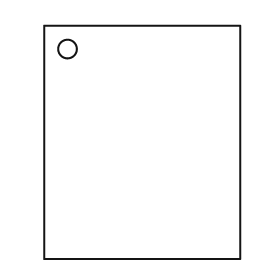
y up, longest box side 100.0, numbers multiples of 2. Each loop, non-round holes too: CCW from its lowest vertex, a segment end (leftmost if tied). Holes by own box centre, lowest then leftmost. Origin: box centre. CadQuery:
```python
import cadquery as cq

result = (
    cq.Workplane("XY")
    .moveTo(-42.0, -50.0)
    .lineTo(42.0, -50.0)
    .lineTo(42.0, 50.0)
    .lineTo(-42.0, 50.0)
    .close()
    .moveTo(-32.0, 40.0)
    .circle(4.0)
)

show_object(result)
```